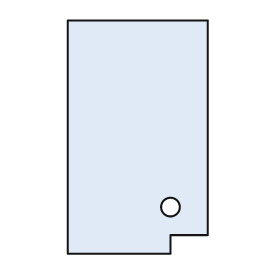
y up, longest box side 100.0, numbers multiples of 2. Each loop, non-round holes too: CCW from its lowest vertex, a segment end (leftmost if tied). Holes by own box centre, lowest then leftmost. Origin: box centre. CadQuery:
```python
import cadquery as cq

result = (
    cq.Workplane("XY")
    .moveTo(-30.0, -50.0)
    .lineTo(14.0, -50.0)
    .lineTo(14.0, -42.0)
    .lineTo(30.0, -42.0)
    .lineTo(30.0, 50.0)
    .lineTo(-30.0, 50.0)
    .close()
    .moveTo(14.0, -30.0)
    .circle(4.0)
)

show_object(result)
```